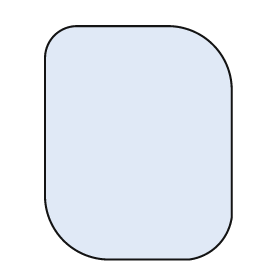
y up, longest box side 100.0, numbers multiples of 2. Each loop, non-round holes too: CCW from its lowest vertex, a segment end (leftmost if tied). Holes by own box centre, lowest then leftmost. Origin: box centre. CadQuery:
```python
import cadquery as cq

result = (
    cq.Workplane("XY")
    .moveTo(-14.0, -50.0)
    .lineTo(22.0, -50.0)
    .threePointArc((34.0, -44.0), (40.0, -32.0))
    .lineTo(40.0, 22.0)
    .threePointArc((32.0, 42.0), (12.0, 50.0))
    .lineTo(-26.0, 50.0)
    .threePointArc((-36.0, 46.0), (-40.0, 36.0))
    .lineTo(-40.0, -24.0)
    .threePointArc((-32.0, -42.0), (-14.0, -50.0))
    .close()
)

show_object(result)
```